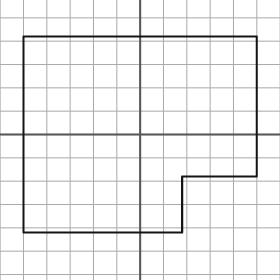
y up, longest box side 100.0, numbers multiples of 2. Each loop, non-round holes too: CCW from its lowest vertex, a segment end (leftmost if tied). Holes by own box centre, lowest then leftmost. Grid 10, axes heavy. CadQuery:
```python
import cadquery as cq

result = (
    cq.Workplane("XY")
    .moveTo(-50.0, -42.0)
    .lineTo(18.0, -42.0)
    .lineTo(18.0, -18.0)
    .lineTo(50.0, -18.0)
    .lineTo(50.0, 42.0)
    .lineTo(-50.0, 42.0)
    .close()
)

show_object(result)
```